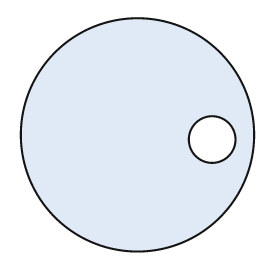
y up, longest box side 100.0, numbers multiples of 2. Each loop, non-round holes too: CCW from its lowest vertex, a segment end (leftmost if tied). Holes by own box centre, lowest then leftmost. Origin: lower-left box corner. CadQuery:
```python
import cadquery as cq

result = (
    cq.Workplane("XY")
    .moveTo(50.0, 50.0)
    .circle(50.0)
    .moveTo(82.0, 48.0)
    .circle(10.0)
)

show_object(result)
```